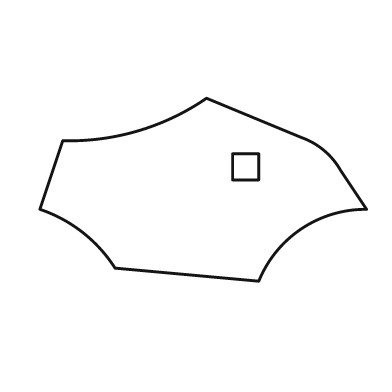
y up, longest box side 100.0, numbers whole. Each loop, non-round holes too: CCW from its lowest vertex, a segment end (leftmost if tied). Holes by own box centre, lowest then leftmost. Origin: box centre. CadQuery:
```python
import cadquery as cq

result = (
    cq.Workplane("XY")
    .moveTo(17.0, -28.0)
    .threePointArc((30.0, -12.0), (50.0, -6.0))
    .lineTo(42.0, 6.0)
    .threePointArc((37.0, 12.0), (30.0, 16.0))
    .lineTo(1.0, 28.0)
    .threePointArc((-20.0, 18.0), (-43.0, 15.0))
    .lineTo(-50.0, -6.0)
    .threePointArc((-37.0, -13.0), (-27.0, -24.0))
    .close()
    .moveTo(9.0, 3.0)
    .lineTo(17.0, 3.0)
    .lineTo(17.0, 11.0)
    .lineTo(9.0, 11.0)
    .close()
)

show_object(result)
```